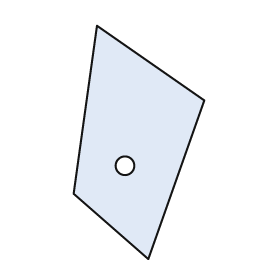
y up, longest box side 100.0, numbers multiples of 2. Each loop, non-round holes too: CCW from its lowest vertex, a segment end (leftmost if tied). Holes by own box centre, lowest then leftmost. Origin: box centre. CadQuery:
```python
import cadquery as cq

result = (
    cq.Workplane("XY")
    .moveTo(4.0, -50.0)
    .lineTo(28.0, 18.0)
    .lineTo(-18.0, 50.0)
    .lineTo(-28.0, -22.0)
    .close()
    .moveTo(-6.0, -10.0)
    .circle(4.0)
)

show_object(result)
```